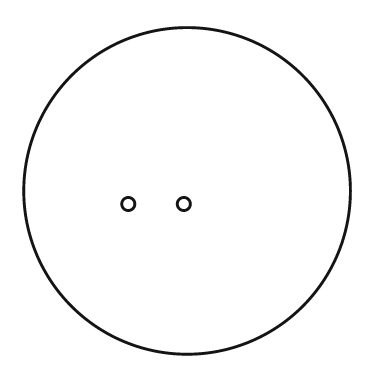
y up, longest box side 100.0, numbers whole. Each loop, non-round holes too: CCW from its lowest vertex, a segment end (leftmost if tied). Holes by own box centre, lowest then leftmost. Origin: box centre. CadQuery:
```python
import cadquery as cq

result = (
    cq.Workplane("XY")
    .moveTo(0.0, 0.0)
    .circle(50.0)
    .moveTo(-18.0, -4.0)
    .circle(2.0)
    .moveTo(-1.0, -4.0)
    .circle(2.0)
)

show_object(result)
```